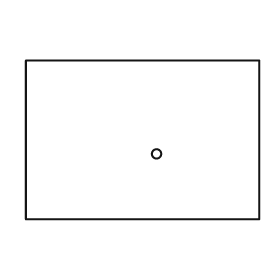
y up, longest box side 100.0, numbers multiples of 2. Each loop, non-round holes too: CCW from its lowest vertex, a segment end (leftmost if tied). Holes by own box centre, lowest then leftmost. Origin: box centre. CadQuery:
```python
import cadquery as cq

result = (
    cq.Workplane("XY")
    .moveTo(-50.0, -34.0)
    .lineTo(50.0, -34.0)
    .lineTo(50.0, 34.0)
    .lineTo(-50.0, 34.0)
    .close()
    .moveTo(6.0, -6.0)
    .circle(2.0)
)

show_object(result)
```